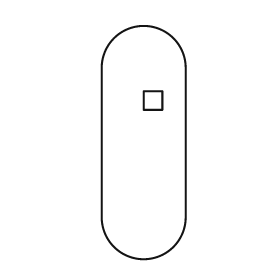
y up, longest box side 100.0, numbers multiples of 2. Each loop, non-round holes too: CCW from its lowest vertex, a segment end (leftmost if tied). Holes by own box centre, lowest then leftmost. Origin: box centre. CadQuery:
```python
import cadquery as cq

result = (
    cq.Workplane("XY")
    .moveTo(-18.0, -32.0)
    .threePointArc((0.0, -50.0), (18.0, -32.0))
    .lineTo(18.0, 32.0)
    .threePointArc((0.0, 50.0), (-18.0, 32.0))
    .close()
    .moveTo(0.0, 14.0)
    .lineTo(8.0, 14.0)
    .lineTo(8.0, 22.0)
    .lineTo(0.0, 22.0)
    .close()
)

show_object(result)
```